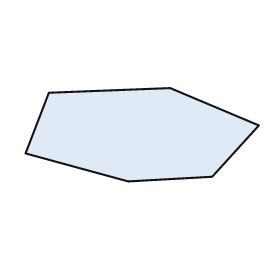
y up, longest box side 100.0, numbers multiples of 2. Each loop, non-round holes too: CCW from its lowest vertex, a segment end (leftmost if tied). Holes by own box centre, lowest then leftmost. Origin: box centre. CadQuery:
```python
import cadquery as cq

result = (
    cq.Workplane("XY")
    .moveTo(-6.0, -20.0)
    .lineTo(30.0, -18.0)
    .lineTo(50.0, 4.0)
    .lineTo(12.0, 20.0)
    .lineTo(-40.0, 18.0)
    .lineTo(-50.0, -8.0)
    .close()
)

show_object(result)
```